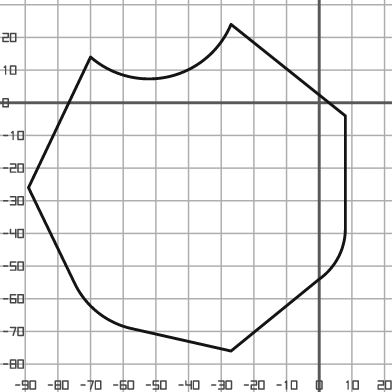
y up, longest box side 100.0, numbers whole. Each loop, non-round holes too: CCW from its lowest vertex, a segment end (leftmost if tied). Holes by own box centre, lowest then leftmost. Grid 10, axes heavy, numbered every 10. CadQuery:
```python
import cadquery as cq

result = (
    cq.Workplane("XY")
    .moveTo(-27.0, -76.0)
    .lineTo(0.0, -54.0)
    .threePointArc((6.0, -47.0), (8.0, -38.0))
    .lineTo(8.0, -4.0)
    .lineTo(-27.0, 24.0)
    .threePointArc((-46.0, 8.0), (-70.0, 14.0))
    .lineTo(-89.0, -26.0)
    .lineTo(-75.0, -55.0)
    .threePointArc((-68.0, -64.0), (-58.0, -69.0))
    .close()
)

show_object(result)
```